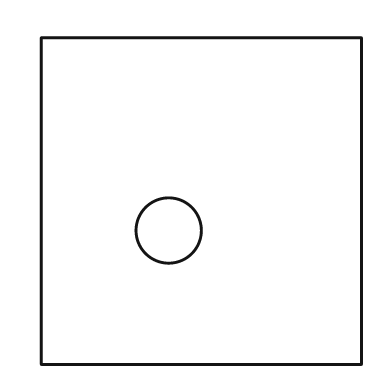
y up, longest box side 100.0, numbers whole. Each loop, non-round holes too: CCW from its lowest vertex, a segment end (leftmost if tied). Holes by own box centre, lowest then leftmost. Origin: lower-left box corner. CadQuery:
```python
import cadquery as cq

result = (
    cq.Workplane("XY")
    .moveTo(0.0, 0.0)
    .lineTo(98.0, 0.0)
    .lineTo(98.0, 100.0)
    .lineTo(0.0, 100.0)
    .close()
    .moveTo(39.0, 41.0)
    .circle(10.0)
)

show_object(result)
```